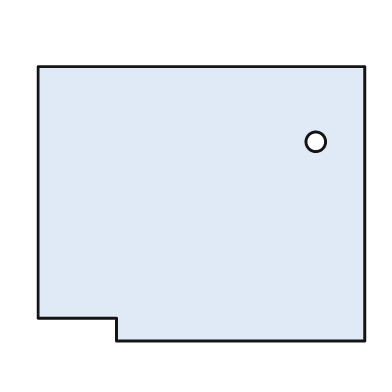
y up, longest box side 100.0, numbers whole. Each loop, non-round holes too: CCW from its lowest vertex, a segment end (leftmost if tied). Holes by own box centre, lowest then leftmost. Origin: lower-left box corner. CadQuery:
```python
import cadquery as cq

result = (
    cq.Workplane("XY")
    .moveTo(24.0, 0.0)
    .lineTo(100.0, 0.0)
    .lineTo(100.0, 84.0)
    .lineTo(0.0, 84.0)
    .lineTo(0.0, 7.0)
    .lineTo(24.0, 7.0)
    .close()
    .moveTo(85.0, 61.0)
    .circle(3.0)
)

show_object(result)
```